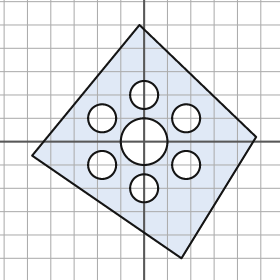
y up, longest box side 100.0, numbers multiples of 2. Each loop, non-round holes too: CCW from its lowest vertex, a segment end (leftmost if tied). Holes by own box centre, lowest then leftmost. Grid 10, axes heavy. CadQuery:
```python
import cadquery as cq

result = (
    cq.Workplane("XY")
    .moveTo(16.0, -50.0)
    .lineTo(48.0, 2.0)
    .lineTo(-2.0, 50.0)
    .lineTo(-48.0, -6.0)
    .close()
    .moveTo(0.0, -20.0)
    .circle(6.0)
    .moveTo(-18.0, -10.0)
    .circle(6.0)
    .moveTo(18.0, -10.0)
    .circle(6.0)
    .moveTo(0.0, 0.0)
    .circle(10.0)
    .moveTo(-18.0, 10.0)
    .circle(6.0)
    .moveTo(18.0, 10.0)
    .circle(6.0)
    .moveTo(0.0, 20.0)
    .circle(6.0)
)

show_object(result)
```